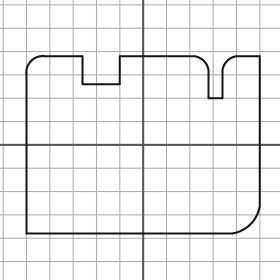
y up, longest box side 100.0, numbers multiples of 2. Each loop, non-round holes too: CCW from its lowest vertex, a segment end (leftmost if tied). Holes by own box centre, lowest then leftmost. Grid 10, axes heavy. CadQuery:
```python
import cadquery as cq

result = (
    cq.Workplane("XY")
    .moveTo(-50.0, -38.0)
    .lineTo(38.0, -38.0)
    .threePointArc((46.0, -34.0), (50.0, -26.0))
    .lineTo(50.0, 38.0)
    .lineTo(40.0, 38.0)
    .threePointArc((36.0, 36.0), (34.0, 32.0))
    .lineTo(34.0, 20.0)
    .lineTo(28.0, 20.0)
    .lineTo(28.0, 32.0)
    .threePointArc((26.0, 36.0), (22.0, 38.0))
    .lineTo(-10.0, 38.0)
    .lineTo(-10.0, 26.0)
    .lineTo(-26.0, 26.0)
    .lineTo(-26.0, 38.0)
    .lineTo(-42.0, 38.0)
    .threePointArc((-48.0, 36.0), (-50.0, 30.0))
    .close()
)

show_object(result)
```